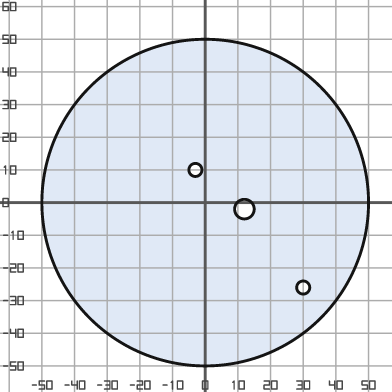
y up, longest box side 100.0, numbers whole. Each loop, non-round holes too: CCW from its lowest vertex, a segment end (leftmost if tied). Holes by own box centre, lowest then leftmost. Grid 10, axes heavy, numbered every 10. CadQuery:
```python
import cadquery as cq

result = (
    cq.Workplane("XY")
    .moveTo(0.0, 0.0)
    .circle(50.0)
    .moveTo(30.0, -26.0)
    .circle(2.0)
    .moveTo(12.0, -2.0)
    .circle(3.0)
    .moveTo(-3.0, 10.0)
    .circle(2.0)
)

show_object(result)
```